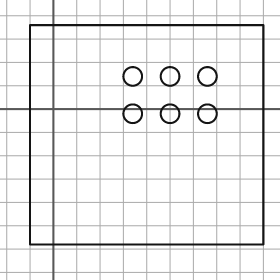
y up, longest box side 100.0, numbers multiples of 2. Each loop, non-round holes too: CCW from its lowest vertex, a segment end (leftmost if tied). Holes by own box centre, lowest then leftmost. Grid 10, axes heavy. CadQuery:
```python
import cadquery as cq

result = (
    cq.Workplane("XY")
    .moveTo(-10.0, -58.0)
    .lineTo(90.0, -58.0)
    .lineTo(90.0, 36.0)
    .lineTo(-10.0, 36.0)
    .close()
    .moveTo(34.0, -2.0)
    .circle(4.0)
    .moveTo(50.0, -2.0)
    .circle(4.0)
    .moveTo(66.0, -2.0)
    .circle(4.0)
    .moveTo(34.0, 14.0)
    .circle(4.0)
    .moveTo(50.0, 14.0)
    .circle(4.0)
    .moveTo(66.0, 14.0)
    .circle(4.0)
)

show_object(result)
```